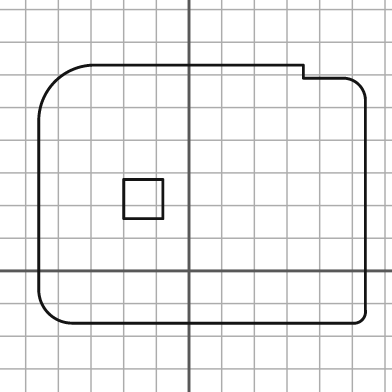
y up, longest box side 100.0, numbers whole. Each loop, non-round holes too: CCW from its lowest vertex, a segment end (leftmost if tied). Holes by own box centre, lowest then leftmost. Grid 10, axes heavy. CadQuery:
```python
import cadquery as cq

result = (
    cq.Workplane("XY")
    .moveTo(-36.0, -16.0)
    .lineTo(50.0, -16.0)
    .threePointArc((53.0, -15.0), (54.0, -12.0))
    .lineTo(54.0, 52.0)
    .threePointArc((52.0, 57.0), (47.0, 59.0))
    .lineTo(35.0, 59.0)
    .lineTo(35.0, 63.0)
    .lineTo(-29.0, 63.0)
    .threePointArc((-41.0, 58.0), (-46.0, 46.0))
    .lineTo(-46.0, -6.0)
    .threePointArc((-43.0, -13.0), (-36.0, -16.0))
    .close()
    .moveTo(-20.0, 16.0)
    .lineTo(-8.0, 16.0)
    .lineTo(-8.0, 28.0)
    .lineTo(-20.0, 28.0)
    .close()
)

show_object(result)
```